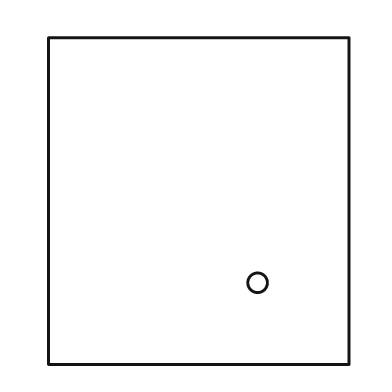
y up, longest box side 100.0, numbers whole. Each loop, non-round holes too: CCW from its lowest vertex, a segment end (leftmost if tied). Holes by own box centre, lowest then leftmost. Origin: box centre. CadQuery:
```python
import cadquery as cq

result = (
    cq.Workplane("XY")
    .moveTo(-46.0, -50.0)
    .lineTo(46.0, -50.0)
    .lineTo(46.0, 50.0)
    .lineTo(-46.0, 50.0)
    .close()
    .moveTo(18.0, -25.0)
    .circle(3.0)
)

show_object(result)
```